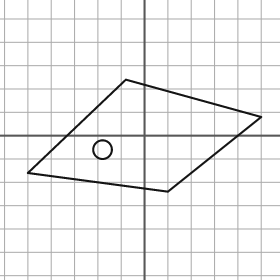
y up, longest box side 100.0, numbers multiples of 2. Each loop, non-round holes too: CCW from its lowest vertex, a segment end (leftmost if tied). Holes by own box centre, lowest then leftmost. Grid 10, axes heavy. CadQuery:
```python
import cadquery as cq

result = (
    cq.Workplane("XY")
    .moveTo(10.0, -24.0)
    .lineTo(50.0, 8.0)
    .lineTo(-8.0, 24.0)
    .lineTo(-50.0, -16.0)
    .close()
    .moveTo(-18.0, -6.0)
    .circle(4.0)
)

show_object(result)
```